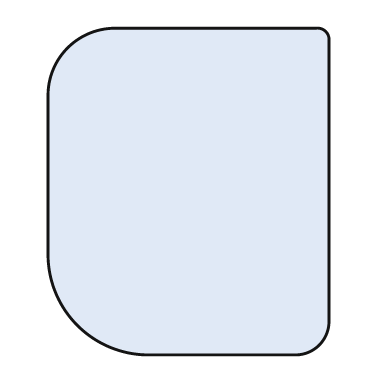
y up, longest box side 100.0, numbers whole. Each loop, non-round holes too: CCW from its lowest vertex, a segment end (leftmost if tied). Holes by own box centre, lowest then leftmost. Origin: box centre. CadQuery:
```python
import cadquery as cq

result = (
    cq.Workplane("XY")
    .moveTo(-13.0, -50.0)
    .lineTo(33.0, -50.0)
    .threePointArc((40.0, -47.0), (43.0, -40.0))
    .lineTo(43.0, 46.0)
    .threePointArc((42.0, 49.0), (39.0, 50.0))
    .lineTo(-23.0, 50.0)
    .threePointArc((-37.0, 44.0), (-43.0, 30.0))
    .lineTo(-43.0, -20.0)
    .threePointArc((-34.0, -41.0), (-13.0, -50.0))
    .close()
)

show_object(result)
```